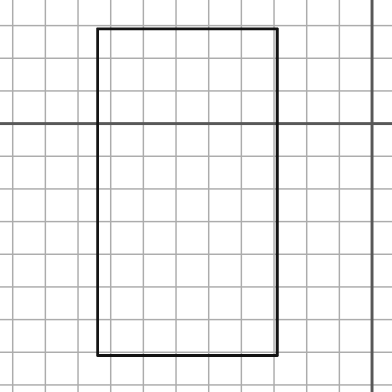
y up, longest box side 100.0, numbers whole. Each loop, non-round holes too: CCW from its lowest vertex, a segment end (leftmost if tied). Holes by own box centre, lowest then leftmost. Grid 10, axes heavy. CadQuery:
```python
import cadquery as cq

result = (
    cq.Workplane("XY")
    .moveTo(-84.0, -71.0)
    .lineTo(-29.0, -71.0)
    .lineTo(-29.0, 29.0)
    .lineTo(-84.0, 29.0)
    .close()
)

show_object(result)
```